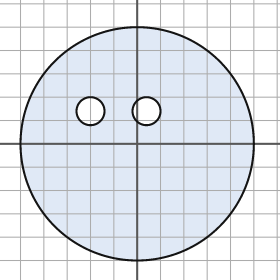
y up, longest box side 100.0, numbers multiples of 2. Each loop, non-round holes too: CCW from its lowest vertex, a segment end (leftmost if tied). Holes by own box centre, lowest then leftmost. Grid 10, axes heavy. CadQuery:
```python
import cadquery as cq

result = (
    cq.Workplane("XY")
    .moveTo(0.0, 0.0)
    .circle(50.0)
    .moveTo(-20.0, 14.0)
    .circle(6.0)
    .moveTo(4.0, 14.0)
    .circle(6.0)
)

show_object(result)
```